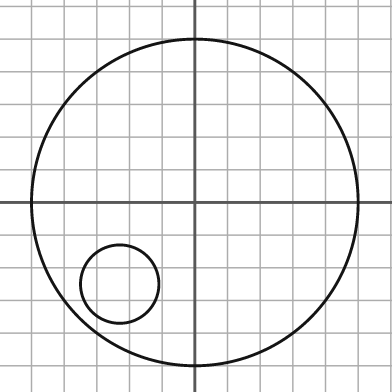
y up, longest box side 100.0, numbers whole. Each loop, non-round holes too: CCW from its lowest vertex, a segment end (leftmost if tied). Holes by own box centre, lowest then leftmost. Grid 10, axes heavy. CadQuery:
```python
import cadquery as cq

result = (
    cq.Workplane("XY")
    .moveTo(0.0, 0.0)
    .circle(50.0)
    .moveTo(-23.0, -25.0)
    .circle(12.0)
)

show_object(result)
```